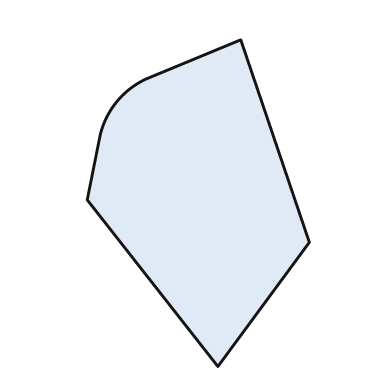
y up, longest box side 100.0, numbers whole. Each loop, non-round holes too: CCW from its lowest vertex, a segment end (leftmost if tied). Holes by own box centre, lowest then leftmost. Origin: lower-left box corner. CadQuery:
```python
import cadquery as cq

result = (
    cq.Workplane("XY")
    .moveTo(40.0, 0.0)
    .lineTo(68.0, 38.0)
    .lineTo(47.0, 100.0)
    .lineTo(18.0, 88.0)
    .threePointArc((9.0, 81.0), (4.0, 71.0))
    .lineTo(0.0, 51.0)
    .close()
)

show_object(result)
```